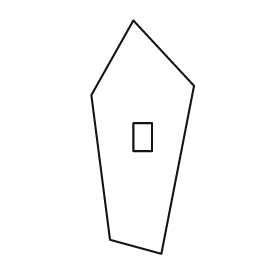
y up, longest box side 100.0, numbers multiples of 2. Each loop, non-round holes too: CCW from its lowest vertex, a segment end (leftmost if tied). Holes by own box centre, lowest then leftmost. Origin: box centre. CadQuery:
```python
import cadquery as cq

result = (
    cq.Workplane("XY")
    .moveTo(8.0, -50.0)
    .lineTo(22.0, 22.0)
    .lineTo(-4.0, 50.0)
    .lineTo(-22.0, 18.0)
    .lineTo(-14.0, -44.0)
    .close()
    .moveTo(-4.0, -6.0)
    .lineTo(4.0, -6.0)
    .lineTo(4.0, 6.0)
    .lineTo(-4.0, 6.0)
    .close()
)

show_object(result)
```